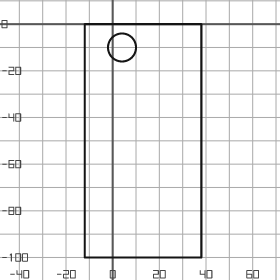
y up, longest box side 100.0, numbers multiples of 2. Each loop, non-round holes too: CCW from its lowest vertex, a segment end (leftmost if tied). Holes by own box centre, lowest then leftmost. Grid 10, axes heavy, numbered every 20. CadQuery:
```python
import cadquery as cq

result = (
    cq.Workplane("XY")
    .moveTo(-12.0, -100.0)
    .lineTo(38.0, -100.0)
    .lineTo(38.0, 0.0)
    .lineTo(-12.0, 0.0)
    .close()
    .moveTo(4.0, -10.0)
    .circle(6.0)
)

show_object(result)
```